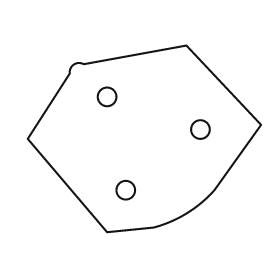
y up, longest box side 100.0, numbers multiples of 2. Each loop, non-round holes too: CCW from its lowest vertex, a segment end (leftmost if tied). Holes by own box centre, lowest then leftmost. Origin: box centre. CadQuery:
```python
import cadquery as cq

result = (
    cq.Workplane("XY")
    .moveTo(-16.0, -40.0)
    .lineTo(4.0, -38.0)
    .threePointArc((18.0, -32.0), (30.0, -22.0))
    .lineTo(50.0, 6.0)
    .lineTo(18.0, 40.0)
    .lineTo(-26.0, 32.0)
    .threePointArc((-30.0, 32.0), (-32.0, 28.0))
    .lineTo(-50.0, 0.0)
    .close()
    .moveTo(-8.0, -22.0)
    .circle(4.0)
    .moveTo(24.0, 4.0)
    .circle(4.0)
    .moveTo(-16.0, 18.0)
    .circle(4.0)
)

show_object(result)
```